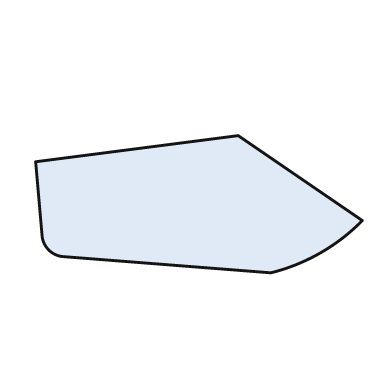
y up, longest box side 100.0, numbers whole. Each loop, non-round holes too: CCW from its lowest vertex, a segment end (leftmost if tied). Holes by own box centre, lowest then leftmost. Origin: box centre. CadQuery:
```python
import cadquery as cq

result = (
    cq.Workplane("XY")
    .moveTo(22.0, -21.0)
    .threePointArc((37.0, -15.0), (50.0, -5.0))
    .lineTo(12.0, 21.0)
    .lineTo(-50.0, 13.0)
    .lineTo(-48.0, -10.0)
    .threePointArc((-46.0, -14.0), (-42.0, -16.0))
    .close()
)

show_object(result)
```